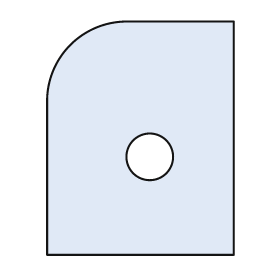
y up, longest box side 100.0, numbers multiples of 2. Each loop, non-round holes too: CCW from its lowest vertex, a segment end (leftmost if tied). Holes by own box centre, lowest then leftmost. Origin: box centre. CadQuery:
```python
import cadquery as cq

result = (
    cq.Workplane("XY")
    .moveTo(-40.0, -50.0)
    .lineTo(40.0, -50.0)
    .lineTo(40.0, 50.0)
    .lineTo(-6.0, 50.0)
    .threePointArc((-30.0, 40.0), (-40.0, 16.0))
    .close()
    .moveTo(4.0, -8.0)
    .circle(10.0)
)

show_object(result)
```